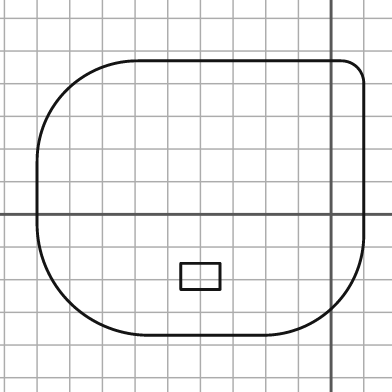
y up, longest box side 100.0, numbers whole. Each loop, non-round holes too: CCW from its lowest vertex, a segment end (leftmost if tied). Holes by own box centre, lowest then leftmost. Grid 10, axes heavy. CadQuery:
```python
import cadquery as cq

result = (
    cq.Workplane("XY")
    .moveTo(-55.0, -37.0)
    .lineTo(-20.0, -37.0)
    .threePointArc((1.0, -28.0), (10.0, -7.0))
    .lineTo(10.0, 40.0)
    .threePointArc((8.0, 45.0), (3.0, 47.0))
    .lineTo(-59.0, 47.0)
    .threePointArc((-81.0, 38.0), (-90.0, 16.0))
    .lineTo(-90.0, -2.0)
    .threePointArc((-80.0, -27.0), (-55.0, -37.0))
    .close()
    .moveTo(-46.0, -23.0)
    .lineTo(-34.0, -23.0)
    .lineTo(-34.0, -15.0)
    .lineTo(-46.0, -15.0)
    .close()
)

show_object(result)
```